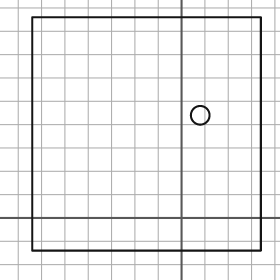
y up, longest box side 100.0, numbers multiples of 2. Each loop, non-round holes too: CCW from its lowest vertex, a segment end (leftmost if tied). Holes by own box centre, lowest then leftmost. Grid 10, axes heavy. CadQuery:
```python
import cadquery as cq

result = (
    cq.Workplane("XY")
    .moveTo(-64.0, -14.0)
    .lineTo(34.0, -14.0)
    .lineTo(34.0, 86.0)
    .lineTo(-64.0, 86.0)
    .close()
    .moveTo(8.0, 44.0)
    .circle(4.0)
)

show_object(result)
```